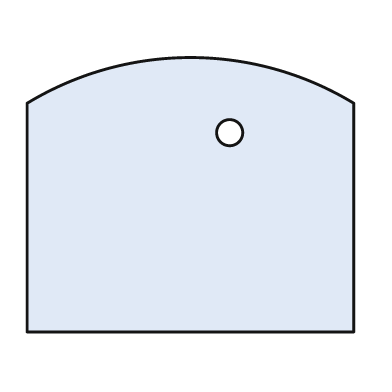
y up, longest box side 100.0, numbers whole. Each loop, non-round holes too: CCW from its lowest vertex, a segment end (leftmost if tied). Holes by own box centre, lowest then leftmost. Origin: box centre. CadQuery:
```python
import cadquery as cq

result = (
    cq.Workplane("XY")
    .moveTo(-50.0, -42.0)
    .lineTo(50.0, -42.0)
    .lineTo(50.0, 28.0)
    .threePointArc((0.0, 42.0), (-50.0, 28.0))
    .close()
    .moveTo(12.0, 19.0)
    .circle(4.0)
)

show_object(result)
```